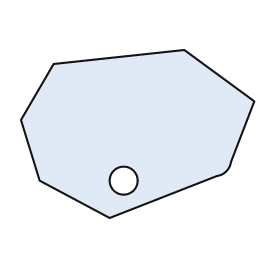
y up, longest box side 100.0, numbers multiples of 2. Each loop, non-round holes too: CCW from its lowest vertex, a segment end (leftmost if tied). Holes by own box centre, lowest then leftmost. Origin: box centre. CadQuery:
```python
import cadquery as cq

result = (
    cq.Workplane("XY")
    .moveTo(-12.0, -36.0)
    .lineTo(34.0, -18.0)
    .threePointArc((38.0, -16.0), (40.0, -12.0))
    .lineTo(50.0, 14.0)
    .lineTo(20.0, 36.0)
    .lineTo(-36.0, 30.0)
    .lineTo(-50.0, 6.0)
    .lineTo(-42.0, -20.0)
    .close()
    .moveTo(-6.0, -20.0)
    .circle(6.0)
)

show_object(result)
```